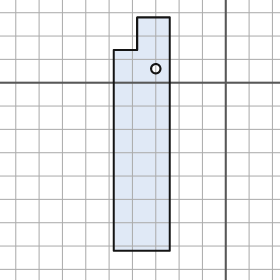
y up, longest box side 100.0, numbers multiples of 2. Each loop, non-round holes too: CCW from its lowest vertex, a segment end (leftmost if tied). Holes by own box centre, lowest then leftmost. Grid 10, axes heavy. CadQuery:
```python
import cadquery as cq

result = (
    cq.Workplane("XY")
    .moveTo(-48.0, -72.0)
    .lineTo(-24.0, -72.0)
    .lineTo(-24.0, 28.0)
    .lineTo(-38.0, 28.0)
    .lineTo(-38.0, 14.0)
    .lineTo(-48.0, 14.0)
    .close()
    .moveTo(-30.0, 6.0)
    .circle(2.0)
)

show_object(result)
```